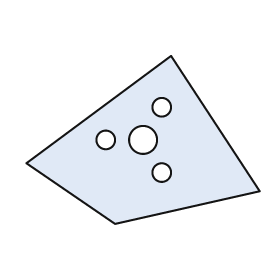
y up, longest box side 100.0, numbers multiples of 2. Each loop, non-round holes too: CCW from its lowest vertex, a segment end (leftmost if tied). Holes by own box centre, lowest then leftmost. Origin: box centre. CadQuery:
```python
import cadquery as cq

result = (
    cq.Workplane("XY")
    .moveTo(-12.0, -36.0)
    .lineTo(50.0, -22.0)
    .lineTo(12.0, 36.0)
    .lineTo(-50.0, -10.0)
    .close()
    .moveTo(8.0, -14.0)
    .circle(4.0)
    .moveTo(-16.0, 0.0)
    .circle(4.0)
    .moveTo(0.0, 0.0)
    .circle(6.0)
    .moveTo(8.0, 14.0)
    .circle(4.0)
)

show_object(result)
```